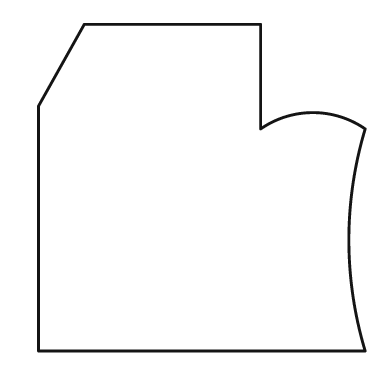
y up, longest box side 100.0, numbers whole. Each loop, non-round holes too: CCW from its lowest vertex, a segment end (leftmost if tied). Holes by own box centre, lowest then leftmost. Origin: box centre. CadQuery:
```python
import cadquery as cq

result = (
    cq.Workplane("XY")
    .moveTo(-50.0, -50.0)
    .lineTo(50.0, -50.0)
    .threePointArc((45.0, -16.0), (50.0, 18.0))
    .threePointArc((34.0, 23.0), (18.0, 18.0))
    .lineTo(18.0, 50.0)
    .lineTo(-36.0, 50.0)
    .lineTo(-50.0, 25.0)
    .close()
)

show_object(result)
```